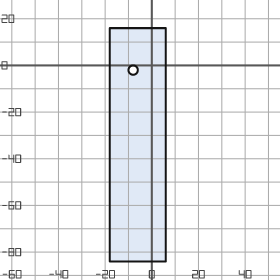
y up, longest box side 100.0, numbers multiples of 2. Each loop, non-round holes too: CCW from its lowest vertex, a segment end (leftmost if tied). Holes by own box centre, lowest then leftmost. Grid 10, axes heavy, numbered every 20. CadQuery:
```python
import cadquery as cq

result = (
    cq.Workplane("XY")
    .moveTo(-18.0, -84.0)
    .lineTo(6.0, -84.0)
    .lineTo(6.0, 16.0)
    .lineTo(-18.0, 16.0)
    .close()
    .moveTo(-8.0, -2.0)
    .circle(2.0)
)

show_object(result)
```